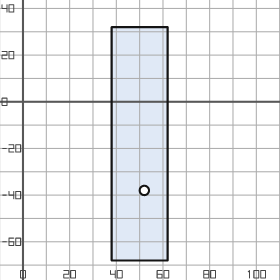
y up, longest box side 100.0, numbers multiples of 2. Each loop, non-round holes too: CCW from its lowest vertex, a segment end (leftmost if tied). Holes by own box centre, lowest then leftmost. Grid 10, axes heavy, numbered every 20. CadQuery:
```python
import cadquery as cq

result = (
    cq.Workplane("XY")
    .moveTo(38.0, -68.0)
    .lineTo(62.0, -68.0)
    .lineTo(62.0, 32.0)
    .lineTo(38.0, 32.0)
    .close()
    .moveTo(52.0, -38.0)
    .circle(2.0)
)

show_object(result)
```